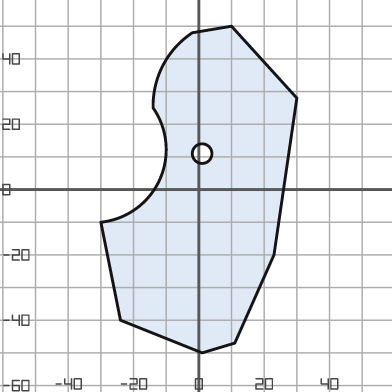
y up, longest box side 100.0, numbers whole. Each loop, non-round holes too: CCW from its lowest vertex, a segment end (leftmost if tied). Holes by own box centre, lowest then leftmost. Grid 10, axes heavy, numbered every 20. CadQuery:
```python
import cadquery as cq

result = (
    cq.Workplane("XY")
    .moveTo(1.0, -50.0)
    .lineTo(11.0, -47.0)
    .lineTo(23.0, -20.0)
    .lineTo(30.0, 28.0)
    .lineTo(10.0, 50.0)
    .lineTo(-2.0, 48.0)
    .threePointArc((-11.0, 38.0), (-14.0, 25.0))
    .threePointArc((-12.0, 3.0), (-30.0, -10.0))
    .lineTo(-24.0, -40.0)
    .close()
    .moveTo(1.0, 11.0)
    .circle(3.0)
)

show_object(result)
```